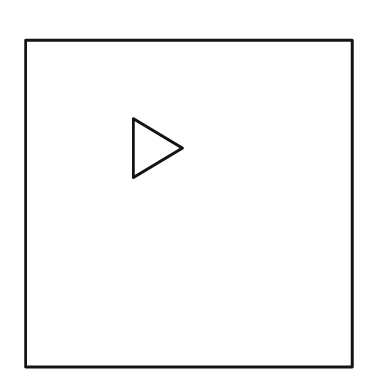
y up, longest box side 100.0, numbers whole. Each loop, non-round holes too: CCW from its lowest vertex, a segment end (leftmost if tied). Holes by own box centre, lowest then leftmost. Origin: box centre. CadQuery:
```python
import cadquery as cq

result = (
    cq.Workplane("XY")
    .moveTo(-50.0, -50.0)
    .lineTo(50.0, -50.0)
    .lineTo(50.0, 50.0)
    .lineTo(-50.0, 50.0)
    .close()
    .moveTo(-17.0, 8.0)
    .lineTo(-2.0, 17.0)
    .lineTo(-17.0, 26.0)
    .close()
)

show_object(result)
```